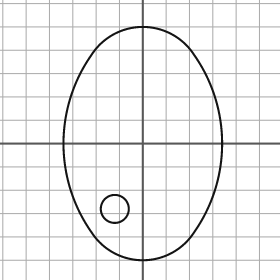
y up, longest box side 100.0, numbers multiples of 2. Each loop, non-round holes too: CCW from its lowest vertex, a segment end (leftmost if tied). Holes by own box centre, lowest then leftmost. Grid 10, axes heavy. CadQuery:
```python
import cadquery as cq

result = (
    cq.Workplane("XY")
    .moveTo(-22.0, -38.0)
    .threePointArc((0.0, -50.0), (22.0, -38.0))
    .threePointArc((34.0, 0.0), (22.0, 38.0))
    .threePointArc((0.0, 50.0), (-22.0, 38.0))
    .threePointArc((-34.0, 0.0), (-22.0, -38.0))
    .close()
    .moveTo(-12.0, -28.0)
    .circle(6.0)
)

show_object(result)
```